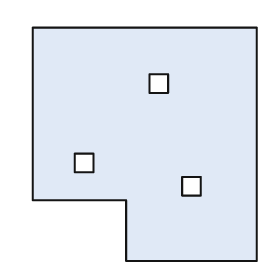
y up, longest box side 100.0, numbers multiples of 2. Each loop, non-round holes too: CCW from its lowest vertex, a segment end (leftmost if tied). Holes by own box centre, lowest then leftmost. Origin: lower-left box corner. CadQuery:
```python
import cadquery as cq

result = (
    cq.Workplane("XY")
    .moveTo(40.0, 0.0)
    .lineTo(96.0, 0.0)
    .lineTo(96.0, 100.0)
    .lineTo(0.0, 100.0)
    .lineTo(0.0, 26.0)
    .lineTo(40.0, 26.0)
    .close()
    .moveTo(64.0, 28.0)
    .lineTo(72.0, 28.0)
    .lineTo(72.0, 36.0)
    .lineTo(64.0, 36.0)
    .close()
    .moveTo(18.0, 38.0)
    .lineTo(26.0, 38.0)
    .lineTo(26.0, 46.0)
    .lineTo(18.0, 46.0)
    .close()
    .moveTo(50.0, 72.0)
    .lineTo(58.0, 72.0)
    .lineTo(58.0, 80.0)
    .lineTo(50.0, 80.0)
    .close()
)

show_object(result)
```